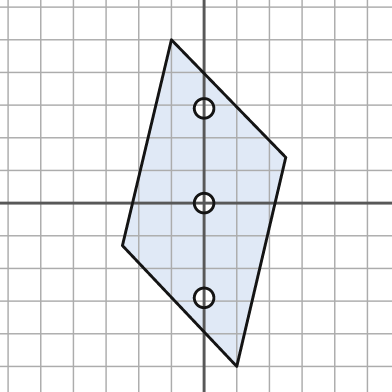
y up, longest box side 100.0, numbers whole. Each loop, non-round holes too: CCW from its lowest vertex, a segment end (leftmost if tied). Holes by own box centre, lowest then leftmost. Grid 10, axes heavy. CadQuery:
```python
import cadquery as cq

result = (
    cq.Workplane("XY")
    .moveTo(10.0, -50.0)
    .lineTo(25.0, 14.0)
    .lineTo(-10.0, 50.0)
    .lineTo(-25.0, -13.0)
    .close()
    .moveTo(0.0, -29.0)
    .circle(3.0)
    .moveTo(0.0, 0.0)
    .circle(3.0)
    .moveTo(0.0, 29.0)
    .circle(3.0)
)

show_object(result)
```